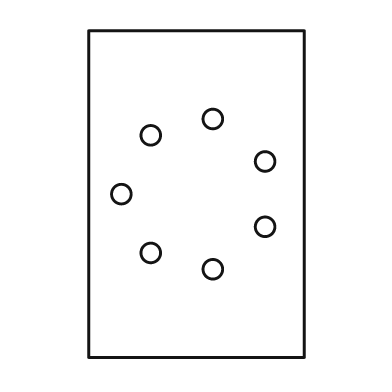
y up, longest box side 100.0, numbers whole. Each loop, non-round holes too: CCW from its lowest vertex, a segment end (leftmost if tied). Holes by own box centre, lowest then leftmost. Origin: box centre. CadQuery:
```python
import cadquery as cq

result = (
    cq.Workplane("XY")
    .moveTo(-33.0, -50.0)
    .lineTo(33.0, -50.0)
    .lineTo(33.0, 50.0)
    .lineTo(-33.0, 50.0)
    .close()
    .moveTo(5.0, -23.0)
    .circle(3.0)
    .moveTo(-14.0, -18.0)
    .circle(3.0)
    .moveTo(21.0, -10.0)
    .circle(3.0)
    .moveTo(-23.0, 0.0)
    .circle(3.0)
    .moveTo(21.0, 10.0)
    .circle(3.0)
    .moveTo(-14.0, 18.0)
    .circle(3.0)
    .moveTo(5.0, 23.0)
    .circle(3.0)
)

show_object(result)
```